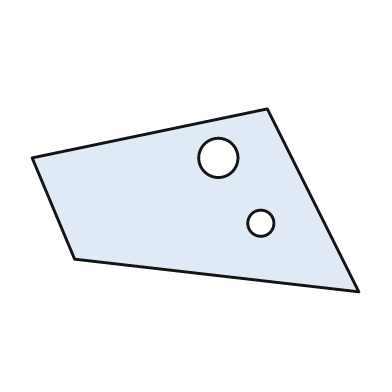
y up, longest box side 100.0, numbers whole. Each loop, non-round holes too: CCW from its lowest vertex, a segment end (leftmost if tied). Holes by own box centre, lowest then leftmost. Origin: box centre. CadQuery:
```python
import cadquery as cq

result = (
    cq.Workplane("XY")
    .moveTo(50.0, -28.0)
    .lineTo(22.0, 28.0)
    .lineTo(-50.0, 13.0)
    .lineTo(-37.0, -18.0)
    .close()
    .moveTo(20.0, -7.0)
    .circle(4.0)
    .moveTo(7.0, 13.0)
    .circle(6.0)
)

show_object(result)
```